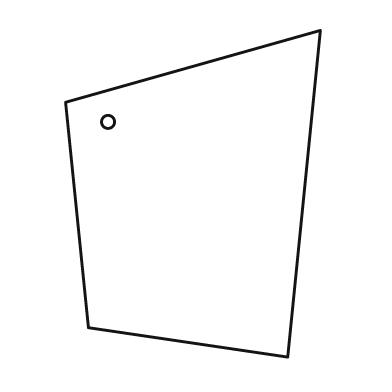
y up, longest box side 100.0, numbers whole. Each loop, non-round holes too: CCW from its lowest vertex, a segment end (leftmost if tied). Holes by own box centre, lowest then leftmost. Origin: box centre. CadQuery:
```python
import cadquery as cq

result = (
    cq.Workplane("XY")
    .moveTo(29.0, -50.0)
    .lineTo(39.0, 50.0)
    .lineTo(-39.0, 28.0)
    .lineTo(-32.0, -41.0)
    .close()
    .moveTo(-26.0, 22.0)
    .circle(2.0)
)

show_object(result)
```